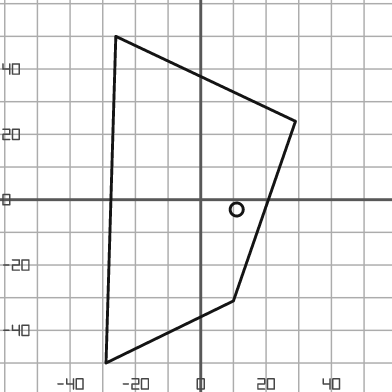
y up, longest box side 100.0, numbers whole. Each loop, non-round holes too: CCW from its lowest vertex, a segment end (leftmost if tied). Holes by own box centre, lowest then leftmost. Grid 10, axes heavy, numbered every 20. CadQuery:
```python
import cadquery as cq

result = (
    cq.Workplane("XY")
    .moveTo(-29.0, -50.0)
    .lineTo(10.0, -31.0)
    .lineTo(29.0, 24.0)
    .lineTo(-26.0, 50.0)
    .close()
    .moveTo(11.0, -3.0)
    .circle(2.0)
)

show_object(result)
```